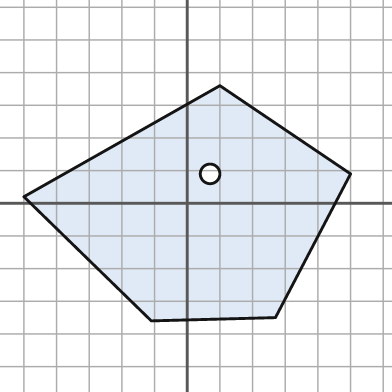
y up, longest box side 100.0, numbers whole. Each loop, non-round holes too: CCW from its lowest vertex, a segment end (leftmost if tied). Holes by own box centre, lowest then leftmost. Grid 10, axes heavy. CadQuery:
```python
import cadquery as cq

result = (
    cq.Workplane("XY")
    .moveTo(-11.0, -36.0)
    .lineTo(27.0, -35.0)
    .lineTo(50.0, 9.0)
    .lineTo(10.0, 36.0)
    .lineTo(-50.0, 2.0)
    .close()
    .moveTo(7.0, 9.0)
    .circle(3.0)
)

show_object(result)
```